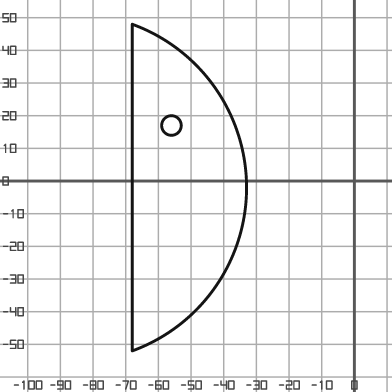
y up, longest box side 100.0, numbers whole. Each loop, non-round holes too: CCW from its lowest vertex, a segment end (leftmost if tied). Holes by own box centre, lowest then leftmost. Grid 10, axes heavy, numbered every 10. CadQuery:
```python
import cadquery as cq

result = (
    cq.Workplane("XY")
    .moveTo(-68.0, -52.0)
    .threePointArc((-33.0, -2.0), (-68.0, 48.0))
    .close()
    .moveTo(-56.0, 17.0)
    .circle(3.0)
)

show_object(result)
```